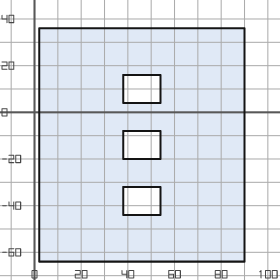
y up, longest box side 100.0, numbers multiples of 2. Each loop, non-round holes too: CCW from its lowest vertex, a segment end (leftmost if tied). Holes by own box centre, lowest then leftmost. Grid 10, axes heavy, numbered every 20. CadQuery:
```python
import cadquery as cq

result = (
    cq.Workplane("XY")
    .moveTo(2.0, -64.0)
    .lineTo(90.0, -64.0)
    .lineTo(90.0, 36.0)
    .lineTo(2.0, 36.0)
    .close()
    .moveTo(38.0, -44.0)
    .lineTo(54.0, -44.0)
    .lineTo(54.0, -32.0)
    .lineTo(38.0, -32.0)
    .close()
    .moveTo(38.0, -20.0)
    .lineTo(54.0, -20.0)
    .lineTo(54.0, -8.0)
    .lineTo(38.0, -8.0)
    .close()
    .moveTo(38.0, 4.0)
    .lineTo(54.0, 4.0)
    .lineTo(54.0, 16.0)
    .lineTo(38.0, 16.0)
    .close()
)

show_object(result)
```